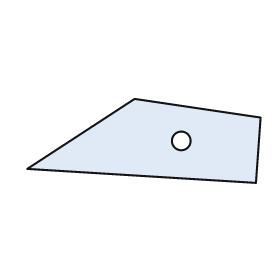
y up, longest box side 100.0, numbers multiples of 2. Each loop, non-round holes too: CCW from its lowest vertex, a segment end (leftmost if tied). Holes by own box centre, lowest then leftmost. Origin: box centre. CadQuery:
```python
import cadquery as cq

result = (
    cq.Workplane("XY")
    .moveTo(48.0, -18.0)
    .lineTo(50.0, 10.0)
    .lineTo(-4.0, 18.0)
    .lineTo(-50.0, -12.0)
    .close()
    .moveTo(16.0, 0.0)
    .circle(4.0)
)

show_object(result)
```